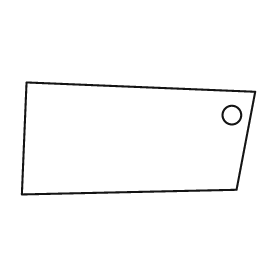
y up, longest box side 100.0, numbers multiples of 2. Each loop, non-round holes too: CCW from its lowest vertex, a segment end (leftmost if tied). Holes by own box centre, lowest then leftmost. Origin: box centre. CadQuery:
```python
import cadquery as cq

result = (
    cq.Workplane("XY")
    .moveTo(-50.0, -24.0)
    .lineTo(42.0, -22.0)
    .lineTo(50.0, 20.0)
    .lineTo(-48.0, 24.0)
    .close()
    .moveTo(40.0, 10.0)
    .circle(4.0)
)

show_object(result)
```